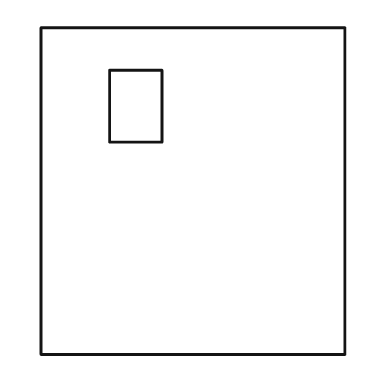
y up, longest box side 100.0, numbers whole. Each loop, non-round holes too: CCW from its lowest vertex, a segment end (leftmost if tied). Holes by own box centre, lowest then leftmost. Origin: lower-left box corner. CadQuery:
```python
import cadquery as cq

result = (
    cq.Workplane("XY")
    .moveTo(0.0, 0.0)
    .lineTo(93.0, 0.0)
    .lineTo(93.0, 100.0)
    .lineTo(0.0, 100.0)
    .close()
    .moveTo(21.0, 65.0)
    .lineTo(37.0, 65.0)
    .lineTo(37.0, 87.0)
    .lineTo(21.0, 87.0)
    .close()
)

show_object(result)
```